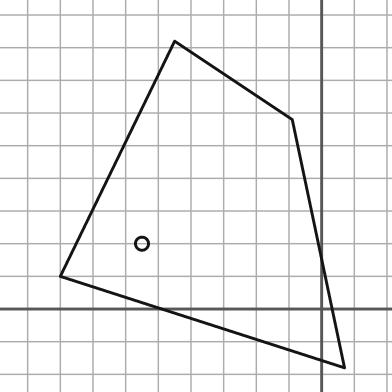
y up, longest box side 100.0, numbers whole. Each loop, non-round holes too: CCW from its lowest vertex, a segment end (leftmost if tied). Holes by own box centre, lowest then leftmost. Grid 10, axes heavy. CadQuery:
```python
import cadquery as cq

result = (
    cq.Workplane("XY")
    .moveTo(7.0, -18.0)
    .lineTo(-9.0, 58.0)
    .lineTo(-45.0, 82.0)
    .lineTo(-80.0, 10.0)
    .close()
    .moveTo(-55.0, 20.0)
    .circle(2.0)
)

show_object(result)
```